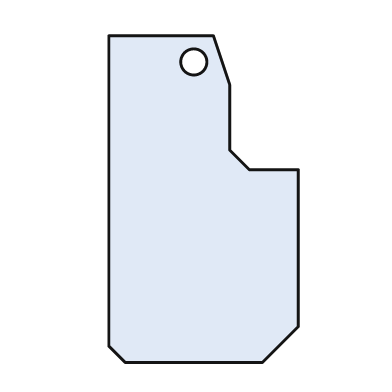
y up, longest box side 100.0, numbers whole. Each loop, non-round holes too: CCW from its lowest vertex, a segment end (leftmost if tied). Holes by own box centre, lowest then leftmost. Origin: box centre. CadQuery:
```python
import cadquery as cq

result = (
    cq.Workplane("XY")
    .moveTo(-24.0, -50.0)
    .lineTo(18.0, -50.0)
    .lineTo(29.0, -39.0)
    .lineTo(29.0, 9.0)
    .lineTo(14.0, 9.0)
    .lineTo(8.0, 15.0)
    .lineTo(8.0, 35.0)
    .lineTo(3.0, 50.0)
    .lineTo(-29.0, 50.0)
    .lineTo(-29.0, -45.0)
    .close()
    .moveTo(-3.0, 42.0)
    .circle(4.0)
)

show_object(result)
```